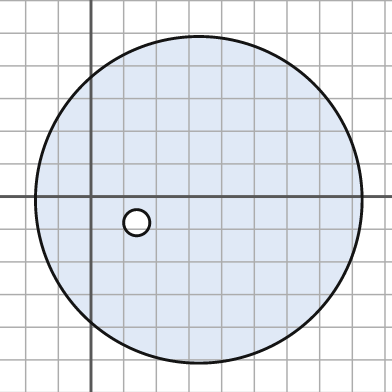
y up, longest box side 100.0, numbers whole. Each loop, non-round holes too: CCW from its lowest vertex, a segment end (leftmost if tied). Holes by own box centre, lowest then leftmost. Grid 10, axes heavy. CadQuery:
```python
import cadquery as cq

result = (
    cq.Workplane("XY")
    .moveTo(33.0, -1.0)
    .circle(50.0)
    .moveTo(14.0, -8.0)
    .circle(4.0)
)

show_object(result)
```